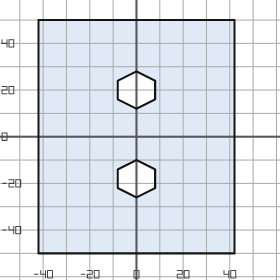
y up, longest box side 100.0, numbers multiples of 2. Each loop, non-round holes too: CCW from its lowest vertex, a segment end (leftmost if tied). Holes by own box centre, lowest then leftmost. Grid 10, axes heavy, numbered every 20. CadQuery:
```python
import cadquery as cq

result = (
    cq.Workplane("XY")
    .moveTo(-42.0, -50.0)
    .lineTo(42.0, -50.0)
    .lineTo(42.0, 50.0)
    .lineTo(-42.0, 50.0)
    .close()
    .moveTo(0.0, -26.0)
    .lineTo(8.0, -22.0)
    .lineTo(8.0, -14.0)
    .lineTo(0.0, -10.0)
    .lineTo(-8.0, -14.0)
    .lineTo(-8.0, -22.0)
    .close()
    .moveTo(0.0, 12.0)
    .lineTo(8.0, 16.0)
    .lineTo(8.0, 24.0)
    .lineTo(0.0, 28.0)
    .lineTo(-8.0, 24.0)
    .lineTo(-8.0, 16.0)
    .close()
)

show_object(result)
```